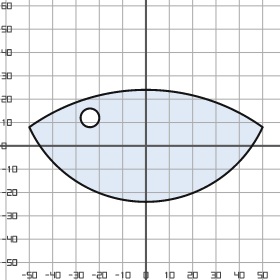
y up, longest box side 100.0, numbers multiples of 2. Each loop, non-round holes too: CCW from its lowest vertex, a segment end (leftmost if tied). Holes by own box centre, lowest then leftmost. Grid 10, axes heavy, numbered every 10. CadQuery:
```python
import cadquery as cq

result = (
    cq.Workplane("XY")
    .moveTo(-50.0, 8.0)
    .threePointArc((0.0, -24.0), (50.0, 8.0))
    .threePointArc((0.0, 24.0), (-50.0, 8.0))
    .close()
    .moveTo(-24.0, 12.0)
    .circle(4.0)
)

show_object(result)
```